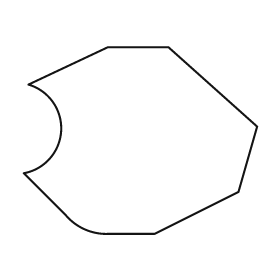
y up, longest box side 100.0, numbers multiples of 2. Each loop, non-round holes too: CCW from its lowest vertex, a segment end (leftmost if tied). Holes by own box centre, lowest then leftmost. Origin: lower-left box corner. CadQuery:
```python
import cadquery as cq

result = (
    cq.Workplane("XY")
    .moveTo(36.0, 0.0)
    .lineTo(56.0, 0.0)
    .lineTo(92.0, 18.0)
    .lineTo(100.0, 46.0)
    .lineTo(62.0, 80.0)
    .lineTo(36.0, 80.0)
    .lineTo(2.0, 64.0)
    .threePointArc((16.0, 44.0), (0.0, 26.0))
    .lineTo(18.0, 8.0)
    .threePointArc((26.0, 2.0), (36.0, 0.0))
    .close()
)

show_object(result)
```